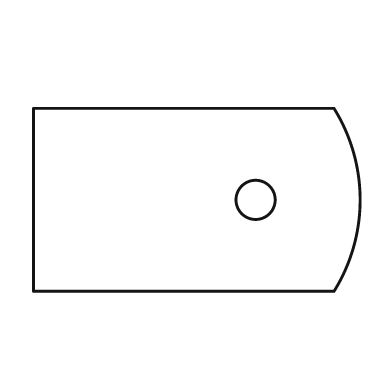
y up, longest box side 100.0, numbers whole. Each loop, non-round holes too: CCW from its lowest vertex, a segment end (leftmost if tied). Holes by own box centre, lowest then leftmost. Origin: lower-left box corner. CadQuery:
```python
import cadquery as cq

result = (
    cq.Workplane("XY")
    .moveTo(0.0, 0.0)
    .lineTo(92.0, 0.0)
    .threePointArc((100.0, 28.0), (92.0, 56.0))
    .lineTo(0.0, 56.0)
    .close()
    .moveTo(68.0, 28.0)
    .circle(6.0)
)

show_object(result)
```